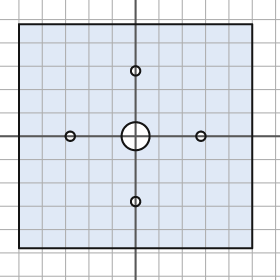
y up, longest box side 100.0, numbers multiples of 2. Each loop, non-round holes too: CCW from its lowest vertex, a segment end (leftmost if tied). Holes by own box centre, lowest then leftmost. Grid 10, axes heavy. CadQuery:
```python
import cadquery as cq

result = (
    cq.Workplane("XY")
    .moveTo(-50.0, -48.0)
    .lineTo(50.0, -48.0)
    .lineTo(50.0, 48.0)
    .lineTo(-50.0, 48.0)
    .close()
    .moveTo(0.0, -28.0)
    .circle(2.0)
    .moveTo(-28.0, 0.0)
    .circle(2.0)
    .moveTo(0.0, 0.0)
    .circle(6.0)
    .moveTo(28.0, 0.0)
    .circle(2.0)
    .moveTo(0.0, 28.0)
    .circle(2.0)
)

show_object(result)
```